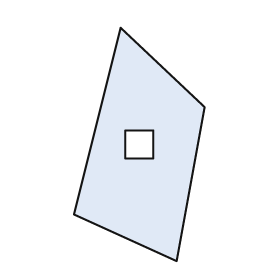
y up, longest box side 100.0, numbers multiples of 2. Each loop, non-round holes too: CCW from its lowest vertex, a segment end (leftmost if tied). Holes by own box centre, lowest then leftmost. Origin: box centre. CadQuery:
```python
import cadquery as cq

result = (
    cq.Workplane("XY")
    .moveTo(16.0, -50.0)
    .lineTo(28.0, 16.0)
    .lineTo(-8.0, 50.0)
    .lineTo(-28.0, -30.0)
    .close()
    .moveTo(-6.0, -6.0)
    .lineTo(6.0, -6.0)
    .lineTo(6.0, 6.0)
    .lineTo(-6.0, 6.0)
    .close()
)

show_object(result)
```